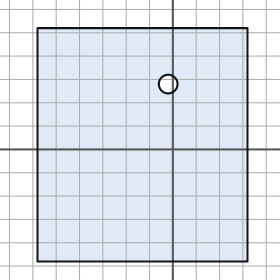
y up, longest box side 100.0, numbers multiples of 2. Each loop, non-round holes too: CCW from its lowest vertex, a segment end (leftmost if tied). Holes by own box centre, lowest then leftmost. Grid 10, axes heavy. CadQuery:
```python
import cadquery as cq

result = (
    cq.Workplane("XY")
    .moveTo(-58.0, -48.0)
    .lineTo(32.0, -48.0)
    .lineTo(32.0, 52.0)
    .lineTo(-58.0, 52.0)
    .close()
    .moveTo(-2.0, 28.0)
    .circle(4.0)
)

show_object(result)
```